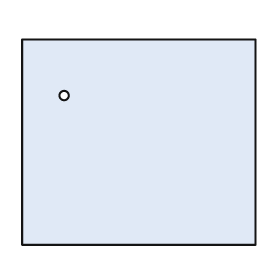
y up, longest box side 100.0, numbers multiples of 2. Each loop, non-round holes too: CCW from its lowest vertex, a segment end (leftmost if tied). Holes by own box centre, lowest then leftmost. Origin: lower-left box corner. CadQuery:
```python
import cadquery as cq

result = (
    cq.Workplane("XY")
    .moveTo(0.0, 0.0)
    .lineTo(100.0, 0.0)
    .lineTo(100.0, 88.0)
    .lineTo(0.0, 88.0)
    .close()
    .moveTo(18.0, 64.0)
    .circle(2.0)
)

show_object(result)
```